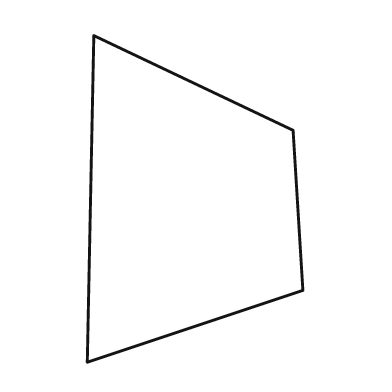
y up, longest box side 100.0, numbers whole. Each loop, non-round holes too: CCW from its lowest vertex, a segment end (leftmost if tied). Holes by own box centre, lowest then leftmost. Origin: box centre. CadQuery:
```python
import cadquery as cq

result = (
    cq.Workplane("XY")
    .moveTo(-33.0, -50.0)
    .lineTo(33.0, -28.0)
    .lineTo(30.0, 21.0)
    .lineTo(-31.0, 50.0)
    .close()
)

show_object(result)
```